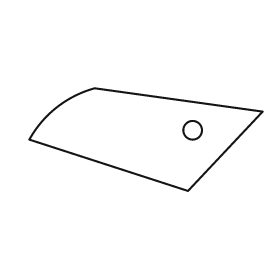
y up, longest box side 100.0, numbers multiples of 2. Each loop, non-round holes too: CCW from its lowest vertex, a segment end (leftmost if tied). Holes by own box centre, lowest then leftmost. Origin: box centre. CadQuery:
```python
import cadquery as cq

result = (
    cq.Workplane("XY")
    .moveTo(18.0, -22.0)
    .lineTo(50.0, 12.0)
    .lineTo(-22.0, 22.0)
    .threePointArc((-38.0, 14.0), (-50.0, 0.0))
    .close()
    .moveTo(20.0, 4.0)
    .circle(4.0)
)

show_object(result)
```